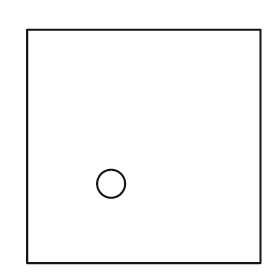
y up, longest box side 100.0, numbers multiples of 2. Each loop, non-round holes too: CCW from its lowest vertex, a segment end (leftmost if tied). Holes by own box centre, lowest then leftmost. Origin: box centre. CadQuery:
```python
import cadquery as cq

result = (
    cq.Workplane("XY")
    .moveTo(-50.0, -50.0)
    .lineTo(50.0, -50.0)
    .lineTo(50.0, 50.0)
    .lineTo(-50.0, 50.0)
    .close()
    .moveTo(-14.0, -16.0)
    .circle(6.0)
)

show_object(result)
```